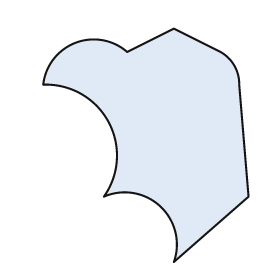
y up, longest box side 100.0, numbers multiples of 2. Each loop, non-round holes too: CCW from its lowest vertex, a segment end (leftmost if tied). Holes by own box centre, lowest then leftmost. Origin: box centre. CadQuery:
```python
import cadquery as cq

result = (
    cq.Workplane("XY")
    .moveTo(12.0, -50.0)
    .lineTo(44.0, -22.0)
    .lineTo(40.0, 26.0)
    .threePointArc((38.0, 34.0), (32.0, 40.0))
    .lineTo(12.0, 50.0)
    .lineTo(-8.0, 40.0)
    .threePointArc((-30.0, 44.0), (-44.0, 26.0))
    .threePointArc((-16.0, 10.0), (-18.0, -22.0))
    .threePointArc((6.0, -26.0), (12.0, -50.0))
    .close()
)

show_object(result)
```